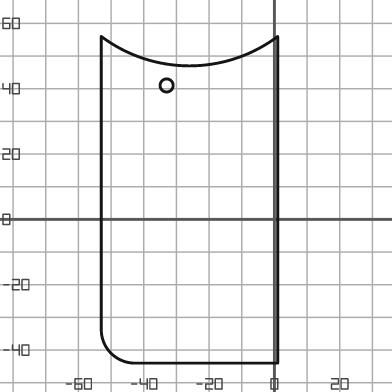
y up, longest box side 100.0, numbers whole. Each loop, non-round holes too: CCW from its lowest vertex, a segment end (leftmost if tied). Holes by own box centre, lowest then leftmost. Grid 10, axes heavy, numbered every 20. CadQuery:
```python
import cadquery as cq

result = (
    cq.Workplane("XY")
    .moveTo(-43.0, -44.0)
    .lineTo(1.0, -44.0)
    .lineTo(1.0, 56.0)
    .threePointArc((-26.0, 47.0), (-53.0, 56.0))
    .lineTo(-53.0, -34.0)
    .threePointArc((-50.0, -41.0), (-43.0, -44.0))
    .close()
    .moveTo(-33.0, 41.0)
    .circle(2.0)
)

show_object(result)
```